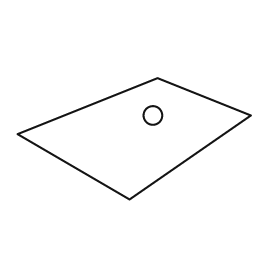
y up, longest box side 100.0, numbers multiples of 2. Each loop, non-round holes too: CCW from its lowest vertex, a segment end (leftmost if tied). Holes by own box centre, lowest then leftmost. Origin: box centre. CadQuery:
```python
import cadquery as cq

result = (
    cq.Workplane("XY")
    .moveTo(-2.0, -26.0)
    .lineTo(50.0, 10.0)
    .lineTo(10.0, 26.0)
    .lineTo(-50.0, 2.0)
    .close()
    .moveTo(8.0, 10.0)
    .circle(4.0)
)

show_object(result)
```